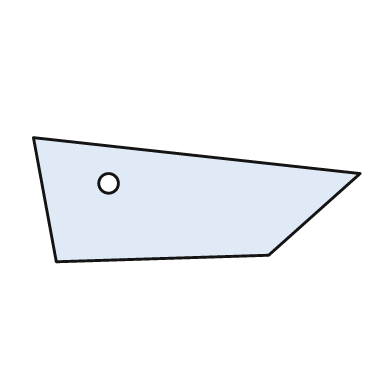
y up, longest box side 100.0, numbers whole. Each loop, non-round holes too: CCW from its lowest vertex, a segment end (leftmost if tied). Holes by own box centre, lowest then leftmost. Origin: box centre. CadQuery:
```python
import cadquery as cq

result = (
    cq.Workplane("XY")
    .moveTo(-43.0, -19.0)
    .lineTo(22.0, -17.0)
    .lineTo(50.0, 8.0)
    .lineTo(-50.0, 19.0)
    .close()
    .moveTo(-27.0, 5.0)
    .circle(3.0)
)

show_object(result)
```